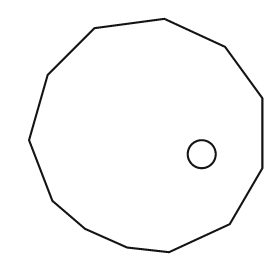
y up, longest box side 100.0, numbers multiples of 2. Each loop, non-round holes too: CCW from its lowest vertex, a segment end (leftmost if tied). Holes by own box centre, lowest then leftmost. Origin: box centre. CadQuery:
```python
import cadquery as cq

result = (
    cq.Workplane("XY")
    .moveTo(10.0, -50.0)
    .lineTo(36.0, -38.0)
    .lineTo(50.0, -14.0)
    .lineTo(50.0, 16.0)
    .lineTo(34.0, 38.0)
    .lineTo(8.0, 50.0)
    .lineTo(-22.0, 46.0)
    .lineTo(-42.0, 26.0)
    .lineTo(-50.0, -2.0)
    .lineTo(-40.0, -28.0)
    .lineTo(-26.0, -40.0)
    .lineTo(-8.0, -48.0)
    .close()
    .moveTo(24.0, -8.0)
    .circle(6.0)
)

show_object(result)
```